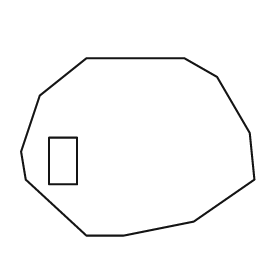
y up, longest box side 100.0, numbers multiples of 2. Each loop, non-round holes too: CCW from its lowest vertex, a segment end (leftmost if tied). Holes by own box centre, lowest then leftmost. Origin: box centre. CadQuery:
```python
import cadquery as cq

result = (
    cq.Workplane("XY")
    .moveTo(-22.0, -38.0)
    .lineTo(-6.0, -38.0)
    .lineTo(24.0, -32.0)
    .lineTo(50.0, -14.0)
    .lineTo(48.0, 6.0)
    .lineTo(34.0, 30.0)
    .lineTo(20.0, 38.0)
    .lineTo(-22.0, 38.0)
    .lineTo(-42.0, 22.0)
    .lineTo(-50.0, -2.0)
    .lineTo(-48.0, -14.0)
    .close()
    .moveTo(-38.0, -16.0)
    .lineTo(-26.0, -16.0)
    .lineTo(-26.0, 4.0)
    .lineTo(-38.0, 4.0)
    .close()
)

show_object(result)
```